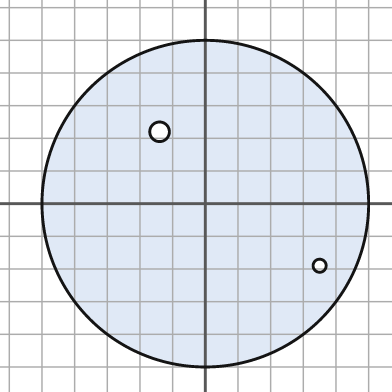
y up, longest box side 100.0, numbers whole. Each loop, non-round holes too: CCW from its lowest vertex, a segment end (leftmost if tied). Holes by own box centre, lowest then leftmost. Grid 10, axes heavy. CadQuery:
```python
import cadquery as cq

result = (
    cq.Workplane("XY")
    .moveTo(0.0, 0.0)
    .circle(50.0)
    .moveTo(35.0, -19.0)
    .circle(2.0)
    .moveTo(-14.0, 22.0)
    .circle(3.0)
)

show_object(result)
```